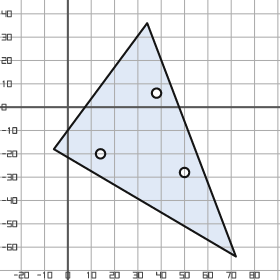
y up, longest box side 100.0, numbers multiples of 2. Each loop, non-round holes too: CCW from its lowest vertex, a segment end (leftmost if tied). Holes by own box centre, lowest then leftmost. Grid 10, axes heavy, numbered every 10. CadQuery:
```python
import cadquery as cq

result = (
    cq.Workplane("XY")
    .moveTo(72.0, -64.0)
    .lineTo(34.0, 36.0)
    .lineTo(-6.0, -18.0)
    .close()
    .moveTo(50.0, -28.0)
    .circle(2.0)
    .moveTo(14.0, -20.0)
    .circle(2.0)
    .moveTo(38.0, 6.0)
    .circle(2.0)
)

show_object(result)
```